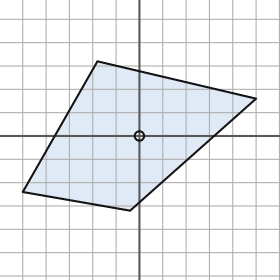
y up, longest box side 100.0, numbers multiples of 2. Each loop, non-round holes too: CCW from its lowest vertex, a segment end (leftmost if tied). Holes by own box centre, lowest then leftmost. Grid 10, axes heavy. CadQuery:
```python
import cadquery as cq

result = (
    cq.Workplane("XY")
    .moveTo(-4.0, -32.0)
    .lineTo(50.0, 16.0)
    .lineTo(-18.0, 32.0)
    .lineTo(-50.0, -24.0)
    .close()
    .moveTo(0.0, 0.0)
    .circle(2.0)
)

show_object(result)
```